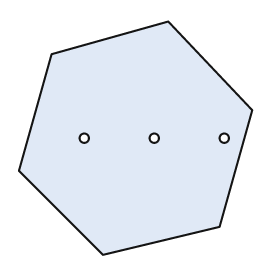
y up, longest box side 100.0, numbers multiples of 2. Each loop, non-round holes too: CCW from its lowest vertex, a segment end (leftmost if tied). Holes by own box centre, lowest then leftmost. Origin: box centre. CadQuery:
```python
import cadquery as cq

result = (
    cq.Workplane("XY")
    .moveTo(-14.0, -50.0)
    .lineTo(36.0, -38.0)
    .lineTo(50.0, 12.0)
    .lineTo(14.0, 50.0)
    .lineTo(-36.0, 36.0)
    .lineTo(-50.0, -14.0)
    .close()
    .moveTo(-22.0, 0.0)
    .circle(2.0)
    .moveTo(8.0, 0.0)
    .circle(2.0)
    .moveTo(38.0, 0.0)
    .circle(2.0)
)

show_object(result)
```